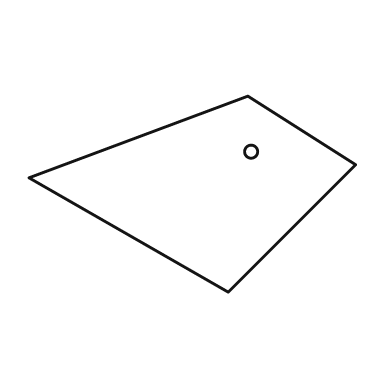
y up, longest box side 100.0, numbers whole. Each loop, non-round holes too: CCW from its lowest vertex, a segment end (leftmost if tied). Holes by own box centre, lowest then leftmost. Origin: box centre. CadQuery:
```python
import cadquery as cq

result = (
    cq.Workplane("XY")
    .moveTo(11.0, -30.0)
    .lineTo(50.0, 9.0)
    .lineTo(17.0, 30.0)
    .lineTo(-50.0, 5.0)
    .close()
    .moveTo(18.0, 13.0)
    .circle(2.0)
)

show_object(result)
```